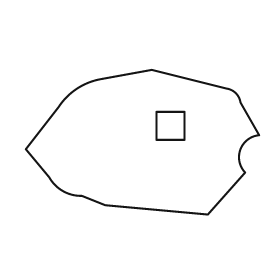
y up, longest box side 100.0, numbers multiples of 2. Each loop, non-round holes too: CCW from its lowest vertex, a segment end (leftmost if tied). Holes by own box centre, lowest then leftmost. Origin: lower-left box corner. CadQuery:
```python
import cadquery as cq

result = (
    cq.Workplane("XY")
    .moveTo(78.0, 0.0)
    .lineTo(94.0, 18.0)
    .threePointArc((92.0, 28.0), (100.0, 34.0))
    .lineTo(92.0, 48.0)
    .threePointArc((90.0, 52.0), (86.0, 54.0))
    .lineTo(54.0, 62.0)
    .lineTo(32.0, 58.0)
    .threePointArc((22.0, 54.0), (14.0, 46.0))
    .lineTo(0.0, 28.0)
    .lineTo(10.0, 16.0)
    .threePointArc((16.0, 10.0), (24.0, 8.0))
    .lineTo(34.0, 4.0)
    .close()
    .moveTo(56.0, 32.0)
    .lineTo(68.0, 32.0)
    .lineTo(68.0, 44.0)
    .lineTo(56.0, 44.0)
    .close()
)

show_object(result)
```